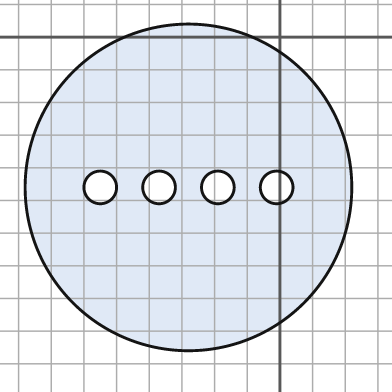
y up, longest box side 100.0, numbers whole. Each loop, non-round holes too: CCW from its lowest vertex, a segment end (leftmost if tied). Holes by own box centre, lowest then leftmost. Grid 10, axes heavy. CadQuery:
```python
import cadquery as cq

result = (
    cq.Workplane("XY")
    .moveTo(-28.0, -46.0)
    .circle(50.0)
    .moveTo(-55.0, -46.0)
    .circle(5.0)
    .moveTo(-37.0, -46.0)
    .circle(5.0)
    .moveTo(-19.0, -46.0)
    .circle(5.0)
    .moveTo(-1.0, -46.0)
    .circle(5.0)
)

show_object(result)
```